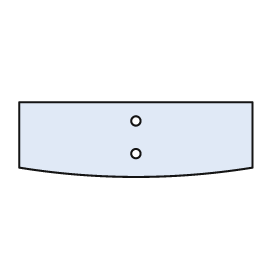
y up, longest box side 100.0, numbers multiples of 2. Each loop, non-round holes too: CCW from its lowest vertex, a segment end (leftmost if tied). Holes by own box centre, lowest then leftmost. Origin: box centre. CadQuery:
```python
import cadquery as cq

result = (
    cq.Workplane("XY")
    .moveTo(-50.0, -12.0)
    .threePointArc((0.0, -16.0), (50.0, -12.0))
    .lineTo(50.0, 16.0)
    .lineTo(-50.0, 16.0)
    .close()
    .moveTo(0.0, -6.0)
    .circle(2.0)
    .moveTo(0.0, 8.0)
    .circle(2.0)
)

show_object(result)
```